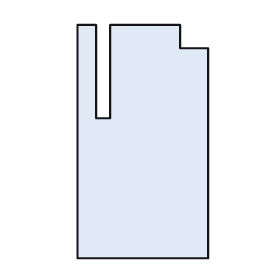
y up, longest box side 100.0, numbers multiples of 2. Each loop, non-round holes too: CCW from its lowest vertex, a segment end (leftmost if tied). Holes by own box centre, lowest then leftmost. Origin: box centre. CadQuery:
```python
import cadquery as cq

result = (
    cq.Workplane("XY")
    .moveTo(-28.0, -50.0)
    .lineTo(28.0, -50.0)
    .lineTo(28.0, 40.0)
    .lineTo(16.0, 40.0)
    .lineTo(16.0, 50.0)
    .lineTo(-14.0, 50.0)
    .lineTo(-14.0, 10.0)
    .lineTo(-20.0, 10.0)
    .lineTo(-20.0, 50.0)
    .lineTo(-28.0, 50.0)
    .close()
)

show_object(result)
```